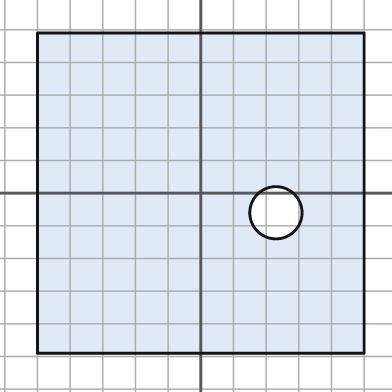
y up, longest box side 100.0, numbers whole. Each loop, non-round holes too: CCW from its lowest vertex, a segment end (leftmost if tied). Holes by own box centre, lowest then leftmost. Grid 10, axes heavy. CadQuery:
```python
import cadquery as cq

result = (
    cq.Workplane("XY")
    .moveTo(-50.0, -49.0)
    .lineTo(50.0, -49.0)
    .lineTo(50.0, 49.0)
    .lineTo(-50.0, 49.0)
    .close()
    .moveTo(23.0, -6.0)
    .circle(8.0)
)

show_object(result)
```